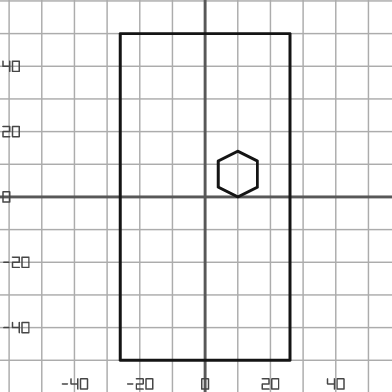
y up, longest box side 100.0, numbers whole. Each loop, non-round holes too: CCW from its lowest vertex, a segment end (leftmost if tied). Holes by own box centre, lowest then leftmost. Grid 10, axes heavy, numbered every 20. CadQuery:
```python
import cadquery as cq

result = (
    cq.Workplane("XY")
    .moveTo(-26.0, -50.0)
    .lineTo(26.0, -50.0)
    .lineTo(26.0, 50.0)
    .lineTo(-26.0, 50.0)
    .close()
    .moveTo(10.0, 0.0)
    .lineTo(16.0, 3.0)
    .lineTo(16.0, 11.0)
    .lineTo(10.0, 14.0)
    .lineTo(4.0, 11.0)
    .lineTo(4.0, 3.0)
    .close()
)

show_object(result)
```